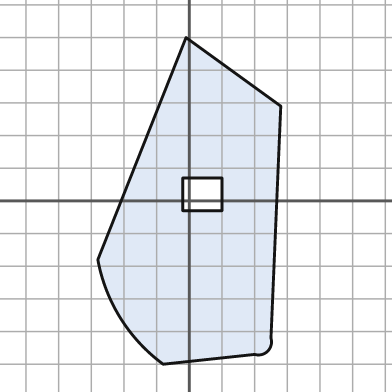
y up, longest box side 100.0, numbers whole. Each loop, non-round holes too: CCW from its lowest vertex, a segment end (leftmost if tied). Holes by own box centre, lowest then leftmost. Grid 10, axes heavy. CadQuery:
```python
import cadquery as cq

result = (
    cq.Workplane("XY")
    .moveTo(-8.0, -50.0)
    .lineTo(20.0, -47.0)
    .threePointArc((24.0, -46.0), (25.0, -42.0))
    .lineTo(28.0, 29.0)
    .lineTo(-1.0, 50.0)
    .lineTo(-28.0, -18.0)
    .threePointArc((-21.0, -36.0), (-8.0, -50.0))
    .close()
    .moveTo(-2.0, -3.0)
    .lineTo(10.0, -3.0)
    .lineTo(10.0, 7.0)
    .lineTo(-2.0, 7.0)
    .close()
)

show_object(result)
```